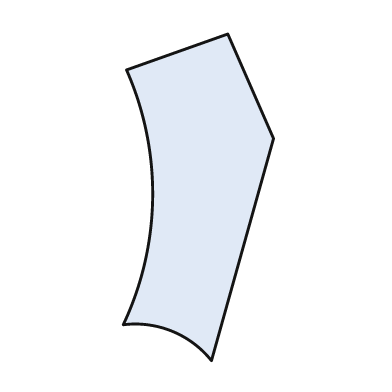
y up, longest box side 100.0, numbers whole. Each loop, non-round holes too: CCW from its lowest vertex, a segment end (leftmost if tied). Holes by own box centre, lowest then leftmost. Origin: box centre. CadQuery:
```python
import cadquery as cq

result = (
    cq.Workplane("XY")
    .moveTo(4.0, -50.0)
    .lineTo(23.0, 18.0)
    .lineTo(9.0, 50.0)
    .lineTo(-22.0, 39.0)
    .threePointArc((-14.0, 0.0), (-23.0, -39.0))
    .threePointArc((-8.0, -41.0), (4.0, -50.0))
    .close()
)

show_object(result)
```